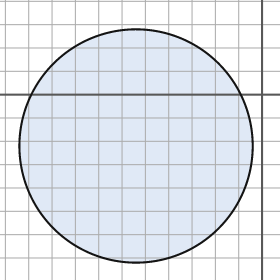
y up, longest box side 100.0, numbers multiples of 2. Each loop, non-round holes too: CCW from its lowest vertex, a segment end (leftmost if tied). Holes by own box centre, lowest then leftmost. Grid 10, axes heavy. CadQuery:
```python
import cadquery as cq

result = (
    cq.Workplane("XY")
    .moveTo(-54.0, -22.0)
    .circle(50.0)
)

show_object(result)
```